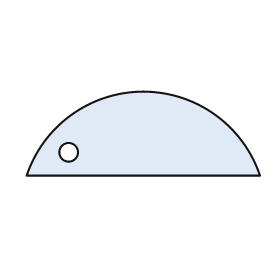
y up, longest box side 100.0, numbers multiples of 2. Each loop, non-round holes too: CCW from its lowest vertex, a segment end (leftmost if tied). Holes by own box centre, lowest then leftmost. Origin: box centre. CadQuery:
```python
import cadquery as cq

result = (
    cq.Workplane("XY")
    .moveTo(-50.0, -18.0)
    .lineTo(50.0, -18.0)
    .threePointArc((0.0, 18.0), (-50.0, -18.0))
    .close()
    .moveTo(-32.0, -8.0)
    .circle(4.0)
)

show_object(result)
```